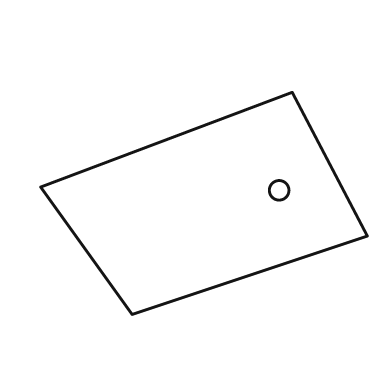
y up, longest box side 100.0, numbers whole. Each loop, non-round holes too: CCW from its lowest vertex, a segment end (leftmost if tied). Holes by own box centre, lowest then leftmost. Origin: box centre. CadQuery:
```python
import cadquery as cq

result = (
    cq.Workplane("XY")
    .moveTo(-22.0, -34.0)
    .lineTo(50.0, -10.0)
    .lineTo(27.0, 34.0)
    .lineTo(-50.0, 5.0)
    .close()
    .moveTo(23.0, 4.0)
    .circle(3.0)
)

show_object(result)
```